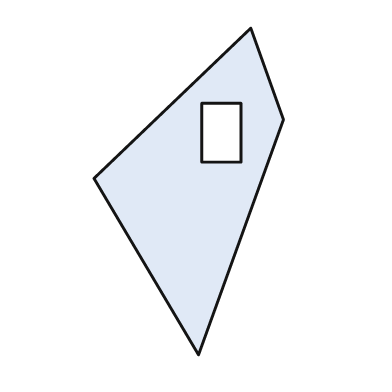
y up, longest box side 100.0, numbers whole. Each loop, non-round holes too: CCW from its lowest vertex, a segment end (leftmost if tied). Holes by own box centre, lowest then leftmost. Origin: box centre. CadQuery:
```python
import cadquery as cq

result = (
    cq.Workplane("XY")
    .moveTo(3.0, -50.0)
    .lineTo(29.0, 22.0)
    .lineTo(19.0, 50.0)
    .lineTo(-29.0, 4.0)
    .close()
    .moveTo(4.0, 9.0)
    .lineTo(16.0, 9.0)
    .lineTo(16.0, 27.0)
    .lineTo(4.0, 27.0)
    .close()
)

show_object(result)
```